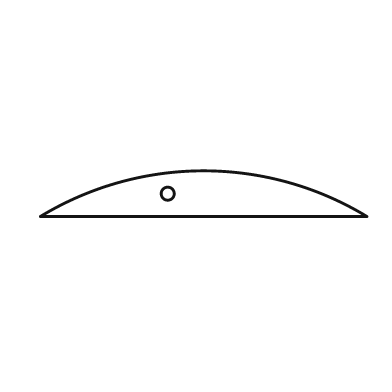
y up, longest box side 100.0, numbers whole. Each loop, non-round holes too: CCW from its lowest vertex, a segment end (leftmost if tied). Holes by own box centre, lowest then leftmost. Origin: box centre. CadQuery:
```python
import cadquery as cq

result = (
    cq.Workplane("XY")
    .moveTo(-50.0, -7.0)
    .lineTo(50.0, -7.0)
    .threePointArc((0.0, 7.0), (-50.0, -7.0))
    .close()
    .moveTo(-11.0, 0.0)
    .circle(2.0)
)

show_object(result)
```